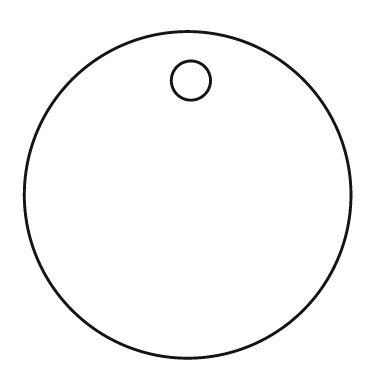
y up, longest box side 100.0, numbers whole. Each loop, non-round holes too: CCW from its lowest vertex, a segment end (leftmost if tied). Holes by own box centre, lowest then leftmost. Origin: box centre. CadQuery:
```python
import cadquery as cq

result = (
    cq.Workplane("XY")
    .moveTo(0.0, 0.0)
    .circle(50.0)
    .moveTo(1.0, 35.0)
    .circle(6.0)
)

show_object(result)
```